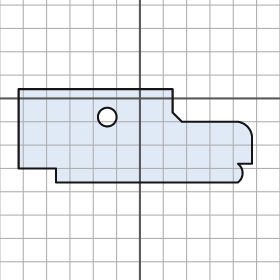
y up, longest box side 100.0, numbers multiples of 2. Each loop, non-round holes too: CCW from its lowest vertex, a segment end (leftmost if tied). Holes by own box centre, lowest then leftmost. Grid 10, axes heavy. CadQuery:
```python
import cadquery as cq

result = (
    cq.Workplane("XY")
    .moveTo(-36.0, -36.0)
    .lineTo(42.0, -36.0)
    .threePointArc((44.0, -32.0), (42.0, -28.0))
    .lineTo(48.0, -28.0)
    .lineTo(48.0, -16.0)
    .threePointArc((46.0, -12.0), (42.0, -10.0))
    .lineTo(18.0, -10.0)
    .lineTo(14.0, -6.0)
    .lineTo(14.0, 4.0)
    .lineTo(-52.0, 4.0)
    .lineTo(-52.0, -30.0)
    .lineTo(-36.0, -30.0)
    .close()
    .moveTo(-14.0, -8.0)
    .circle(4.0)
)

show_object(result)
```